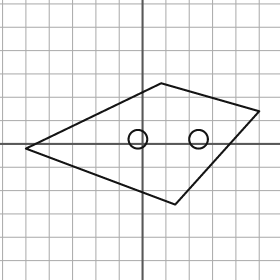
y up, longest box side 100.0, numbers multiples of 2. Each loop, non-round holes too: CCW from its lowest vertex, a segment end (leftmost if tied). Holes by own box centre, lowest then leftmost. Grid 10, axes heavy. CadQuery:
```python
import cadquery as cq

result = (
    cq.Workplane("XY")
    .moveTo(14.0, -26.0)
    .lineTo(50.0, 14.0)
    .lineTo(8.0, 26.0)
    .lineTo(-50.0, -2.0)
    .close()
    .moveTo(-2.0, 2.0)
    .circle(4.0)
    .moveTo(24.0, 2.0)
    .circle(4.0)
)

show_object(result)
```